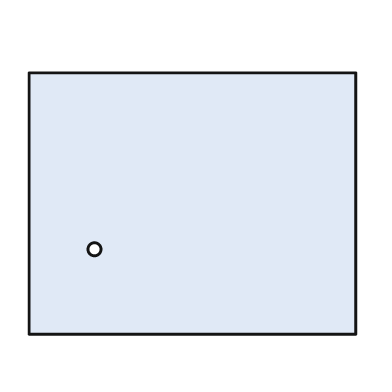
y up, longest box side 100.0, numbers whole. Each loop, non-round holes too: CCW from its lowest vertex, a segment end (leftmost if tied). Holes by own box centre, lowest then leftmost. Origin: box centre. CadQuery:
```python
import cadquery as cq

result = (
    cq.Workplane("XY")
    .moveTo(-50.0, -40.0)
    .lineTo(50.0, -40.0)
    .lineTo(50.0, 40.0)
    .lineTo(-50.0, 40.0)
    .close()
    .moveTo(-30.0, -14.0)
    .circle(2.0)
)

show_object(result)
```